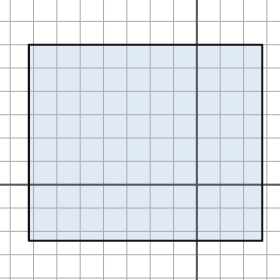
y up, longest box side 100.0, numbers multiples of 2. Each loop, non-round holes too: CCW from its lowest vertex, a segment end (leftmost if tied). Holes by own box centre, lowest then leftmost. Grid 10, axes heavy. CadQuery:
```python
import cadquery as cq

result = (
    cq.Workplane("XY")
    .moveTo(-72.0, -24.0)
    .lineTo(28.0, -24.0)
    .lineTo(28.0, 60.0)
    .lineTo(-72.0, 60.0)
    .close()
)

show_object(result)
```